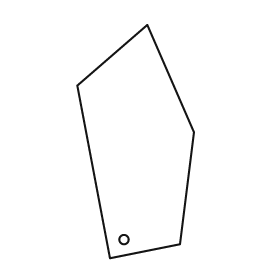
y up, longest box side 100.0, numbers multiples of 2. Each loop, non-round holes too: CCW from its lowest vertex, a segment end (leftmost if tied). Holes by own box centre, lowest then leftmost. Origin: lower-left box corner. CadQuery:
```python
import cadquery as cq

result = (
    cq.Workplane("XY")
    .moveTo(14.0, 0.0)
    .lineTo(44.0, 6.0)
    .lineTo(50.0, 54.0)
    .lineTo(30.0, 100.0)
    .lineTo(0.0, 74.0)
    .close()
    .moveTo(20.0, 8.0)
    .circle(2.0)
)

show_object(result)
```